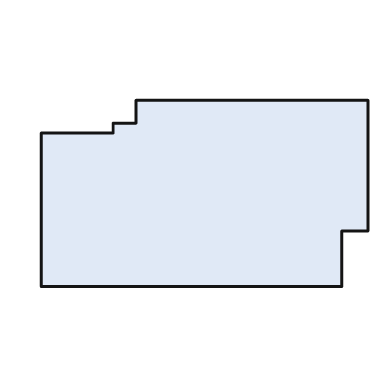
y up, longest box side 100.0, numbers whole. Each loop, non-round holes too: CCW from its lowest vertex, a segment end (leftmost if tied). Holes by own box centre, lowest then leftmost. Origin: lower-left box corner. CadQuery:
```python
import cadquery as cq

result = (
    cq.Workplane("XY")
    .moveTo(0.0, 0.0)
    .lineTo(92.0, 0.0)
    .lineTo(92.0, 17.0)
    .lineTo(100.0, 17.0)
    .lineTo(100.0, 57.0)
    .lineTo(29.0, 57.0)
    .lineTo(29.0, 50.0)
    .lineTo(22.0, 50.0)
    .lineTo(22.0, 47.0)
    .lineTo(0.0, 47.0)
    .close()
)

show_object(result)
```